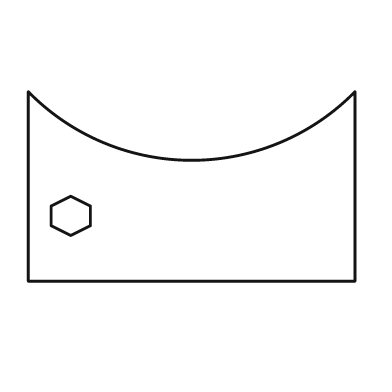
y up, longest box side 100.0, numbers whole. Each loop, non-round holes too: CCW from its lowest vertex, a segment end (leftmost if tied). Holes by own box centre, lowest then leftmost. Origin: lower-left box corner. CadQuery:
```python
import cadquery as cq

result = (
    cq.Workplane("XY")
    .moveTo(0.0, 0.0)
    .lineTo(100.0, 0.0)
    .lineTo(100.0, 58.0)
    .threePointArc((50.0, 37.0), (0.0, 58.0))
    .close()
    .moveTo(13.0, 14.0)
    .lineTo(19.0, 17.0)
    .lineTo(19.0, 23.0)
    .lineTo(13.0, 26.0)
    .lineTo(7.0, 23.0)
    .lineTo(7.0, 17.0)
    .close()
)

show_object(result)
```